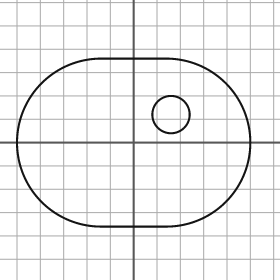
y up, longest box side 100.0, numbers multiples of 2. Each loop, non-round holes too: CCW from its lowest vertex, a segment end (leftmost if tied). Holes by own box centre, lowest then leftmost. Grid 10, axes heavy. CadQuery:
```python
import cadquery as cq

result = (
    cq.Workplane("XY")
    .moveTo(-14.0, -36.0)
    .lineTo(14.0, -36.0)
    .threePointArc((50.0, 0.0), (14.0, 36.0))
    .lineTo(-14.0, 36.0)
    .threePointArc((-50.0, 0.0), (-14.0, -36.0))
    .close()
    .moveTo(16.0, 12.0)
    .circle(8.0)
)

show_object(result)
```